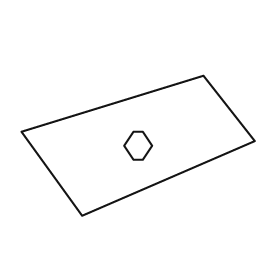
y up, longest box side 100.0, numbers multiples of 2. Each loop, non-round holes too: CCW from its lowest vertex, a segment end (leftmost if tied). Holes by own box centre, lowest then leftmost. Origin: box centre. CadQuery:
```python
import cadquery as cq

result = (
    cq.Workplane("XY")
    .moveTo(-24.0, -30.0)
    .lineTo(50.0, 2.0)
    .lineTo(28.0, 30.0)
    .lineTo(-50.0, 6.0)
    .close()
    .moveTo(-2.0, -6.0)
    .lineTo(2.0, -6.0)
    .lineTo(6.0, 0.0)
    .lineTo(2.0, 6.0)
    .lineTo(-2.0, 6.0)
    .lineTo(-6.0, 0.0)
    .close()
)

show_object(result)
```